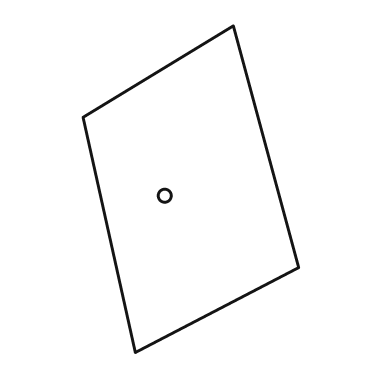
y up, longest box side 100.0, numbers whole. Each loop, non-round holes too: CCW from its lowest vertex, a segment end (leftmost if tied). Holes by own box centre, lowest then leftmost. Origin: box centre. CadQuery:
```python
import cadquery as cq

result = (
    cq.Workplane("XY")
    .moveTo(-17.0, -50.0)
    .lineTo(33.0, -24.0)
    .lineTo(13.0, 50.0)
    .lineTo(-33.0, 22.0)
    .close()
    .moveTo(-8.0, -2.0)
    .circle(2.0)
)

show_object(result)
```